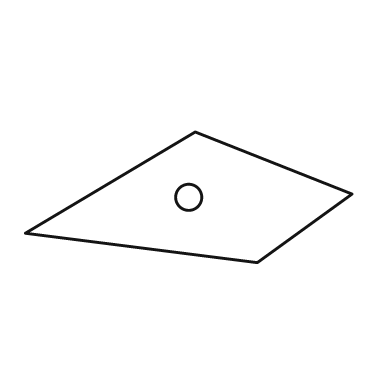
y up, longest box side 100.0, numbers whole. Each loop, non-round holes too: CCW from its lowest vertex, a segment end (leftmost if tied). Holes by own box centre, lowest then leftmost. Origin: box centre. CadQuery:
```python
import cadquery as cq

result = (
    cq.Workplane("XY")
    .moveTo(21.0, -20.0)
    .lineTo(50.0, 1.0)
    .lineTo(2.0, 20.0)
    .lineTo(-50.0, -11.0)
    .close()
    .moveTo(0.0, 0.0)
    .circle(4.0)
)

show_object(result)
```